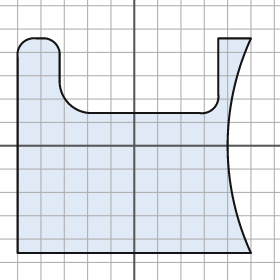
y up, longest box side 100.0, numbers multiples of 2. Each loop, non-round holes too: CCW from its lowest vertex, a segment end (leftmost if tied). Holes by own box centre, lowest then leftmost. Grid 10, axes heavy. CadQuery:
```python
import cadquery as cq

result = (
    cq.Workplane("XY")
    .moveTo(-50.0, -46.0)
    .lineTo(50.0, -46.0)
    .threePointArc((40.0, 0.0), (50.0, 46.0))
    .lineTo(36.0, 46.0)
    .lineTo(36.0, 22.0)
    .threePointArc((34.0, 16.0), (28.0, 14.0))
    .lineTo(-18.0, 14.0)
    .threePointArc((-28.0, 18.0), (-32.0, 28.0))
    .lineTo(-32.0, 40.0)
    .threePointArc((-34.0, 44.0), (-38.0, 46.0))
    .lineTo(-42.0, 46.0)
    .threePointArc((-48.0, 44.0), (-50.0, 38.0))
    .close()
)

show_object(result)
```